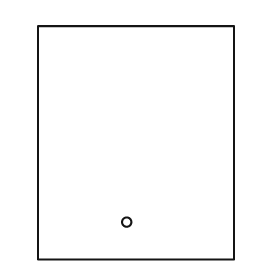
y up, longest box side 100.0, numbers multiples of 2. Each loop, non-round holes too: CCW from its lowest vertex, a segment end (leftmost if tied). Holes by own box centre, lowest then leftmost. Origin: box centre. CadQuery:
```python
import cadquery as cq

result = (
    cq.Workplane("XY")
    .moveTo(-42.0, -50.0)
    .lineTo(42.0, -50.0)
    .lineTo(42.0, 50.0)
    .lineTo(-42.0, 50.0)
    .close()
    .moveTo(-4.0, -34.0)
    .circle(2.0)
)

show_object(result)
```